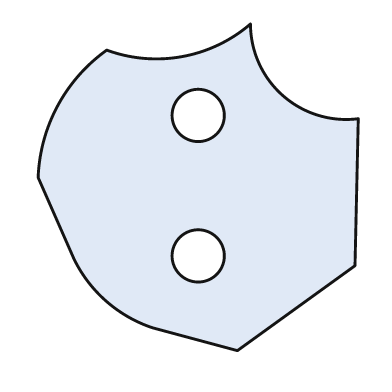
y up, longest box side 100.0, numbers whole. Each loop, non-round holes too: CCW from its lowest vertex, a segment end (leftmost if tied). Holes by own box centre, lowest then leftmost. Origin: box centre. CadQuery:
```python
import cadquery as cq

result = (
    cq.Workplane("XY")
    .moveTo(12.0, -50.0)
    .lineTo(48.0, -24.0)
    .lineTo(49.0, 21.0)
    .threePointArc((26.0, 28.0), (16.0, 50.0))
    .threePointArc((-5.0, 40.0), (-28.0, 42.0))
    .threePointArc((-43.0, 25.0), (-49.0, 3.0))
    .lineTo(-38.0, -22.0)
    .threePointArc((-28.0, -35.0), (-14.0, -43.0))
    .close()
    .moveTo(0.0, -21.0)
    .circle(8.0)
    .moveTo(0.0, 22.0)
    .circle(8.0)
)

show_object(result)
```